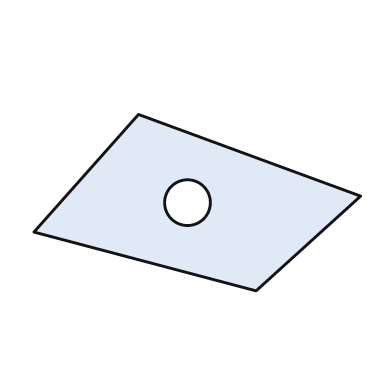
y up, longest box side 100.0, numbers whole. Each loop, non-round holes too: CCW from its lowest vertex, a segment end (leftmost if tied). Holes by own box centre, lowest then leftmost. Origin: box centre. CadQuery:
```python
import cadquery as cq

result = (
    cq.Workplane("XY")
    .moveTo(18.0, -27.0)
    .lineTo(50.0, 2.0)
    .lineTo(-18.0, 27.0)
    .lineTo(-50.0, -9.0)
    .close()
    .moveTo(-3.0, 0.0)
    .circle(7.0)
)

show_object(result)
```